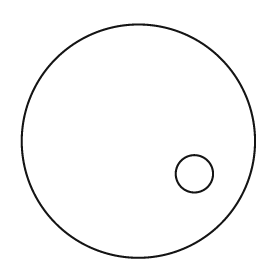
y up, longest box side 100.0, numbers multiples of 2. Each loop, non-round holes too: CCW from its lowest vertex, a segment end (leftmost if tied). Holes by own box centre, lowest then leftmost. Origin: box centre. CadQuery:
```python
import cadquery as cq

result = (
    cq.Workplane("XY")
    .moveTo(0.0, 0.0)
    .circle(50.0)
    .moveTo(24.0, -14.0)
    .circle(8.0)
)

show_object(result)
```